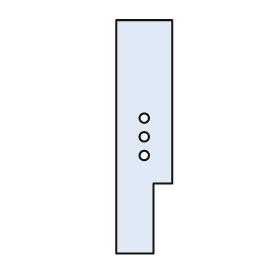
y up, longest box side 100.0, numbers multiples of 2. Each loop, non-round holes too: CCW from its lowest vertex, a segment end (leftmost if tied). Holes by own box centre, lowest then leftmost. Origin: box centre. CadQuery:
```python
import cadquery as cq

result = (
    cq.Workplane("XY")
    .moveTo(-12.0, -50.0)
    .lineTo(4.0, -50.0)
    .lineTo(4.0, -20.0)
    .lineTo(12.0, -20.0)
    .lineTo(12.0, 50.0)
    .lineTo(-12.0, 50.0)
    .close()
    .moveTo(0.0, -8.0)
    .circle(2.0)
    .moveTo(0.0, 0.0)
    .circle(2.0)
    .moveTo(0.0, 8.0)
    .circle(2.0)
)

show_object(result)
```